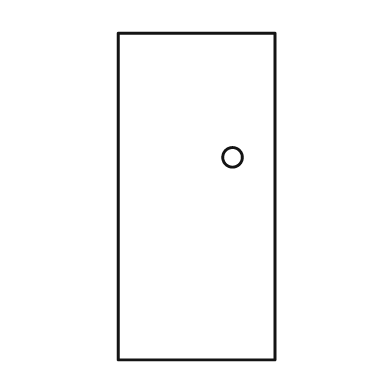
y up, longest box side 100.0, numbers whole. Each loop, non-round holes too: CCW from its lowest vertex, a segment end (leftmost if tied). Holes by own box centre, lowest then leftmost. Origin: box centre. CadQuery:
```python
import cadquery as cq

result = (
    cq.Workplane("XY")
    .moveTo(-24.0, -50.0)
    .lineTo(24.0, -50.0)
    .lineTo(24.0, 50.0)
    .lineTo(-24.0, 50.0)
    .close()
    .moveTo(11.0, 12.0)
    .circle(3.0)
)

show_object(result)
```